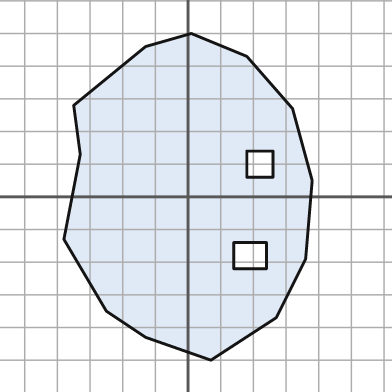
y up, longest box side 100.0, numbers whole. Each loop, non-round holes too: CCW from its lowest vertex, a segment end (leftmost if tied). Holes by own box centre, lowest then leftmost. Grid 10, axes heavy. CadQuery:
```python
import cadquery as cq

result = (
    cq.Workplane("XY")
    .moveTo(7.0, -50.0)
    .lineTo(27.0, -37.0)
    .lineTo(36.0, -19.0)
    .lineTo(38.0, 5.0)
    .lineTo(32.0, 27.0)
    .lineTo(18.0, 43.0)
    .lineTo(1.0, 50.0)
    .lineTo(-13.0, 46.0)
    .lineTo(-35.0, 28.0)
    .lineTo(-33.0, 13.0)
    .lineTo(-38.0, -13.0)
    .lineTo(-25.0, -35.0)
    .lineTo(-13.0, -43.0)
    .close()
    .moveTo(14.0, -22.0)
    .lineTo(24.0, -22.0)
    .lineTo(24.0, -14.0)
    .lineTo(14.0, -14.0)
    .close()
    .moveTo(18.0, 6.0)
    .lineTo(26.0, 6.0)
    .lineTo(26.0, 14.0)
    .lineTo(18.0, 14.0)
    .close()
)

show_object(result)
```